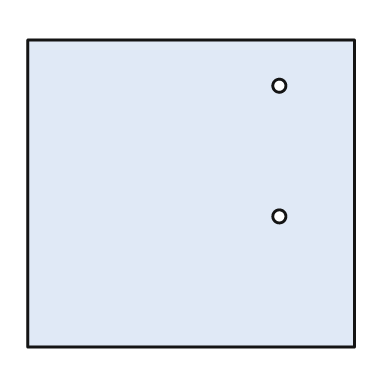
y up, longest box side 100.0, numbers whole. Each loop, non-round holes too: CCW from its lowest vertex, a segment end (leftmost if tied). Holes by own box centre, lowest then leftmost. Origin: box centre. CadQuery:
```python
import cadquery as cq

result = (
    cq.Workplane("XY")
    .moveTo(-50.0, -47.0)
    .lineTo(50.0, -47.0)
    .lineTo(50.0, 47.0)
    .lineTo(-50.0, 47.0)
    .close()
    .moveTo(27.0, -7.0)
    .circle(2.0)
    .moveTo(27.0, 33.0)
    .circle(2.0)
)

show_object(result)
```